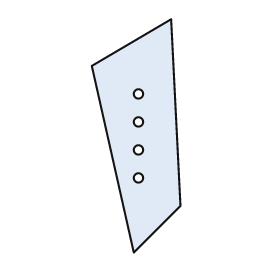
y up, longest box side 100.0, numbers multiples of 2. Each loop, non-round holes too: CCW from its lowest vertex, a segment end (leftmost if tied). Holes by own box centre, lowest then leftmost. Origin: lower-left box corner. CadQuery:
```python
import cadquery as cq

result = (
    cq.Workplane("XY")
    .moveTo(18.0, 0.0)
    .lineTo(38.0, 20.0)
    .lineTo(34.0, 100.0)
    .lineTo(0.0, 80.0)
    .close()
    .moveTo(20.0, 32.0)
    .circle(2.0)
    .moveTo(20.0, 44.0)
    .circle(2.0)
    .moveTo(20.0, 56.0)
    .circle(2.0)
    .moveTo(20.0, 68.0)
    .circle(2.0)
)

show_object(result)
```